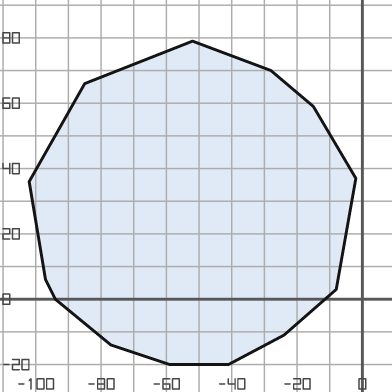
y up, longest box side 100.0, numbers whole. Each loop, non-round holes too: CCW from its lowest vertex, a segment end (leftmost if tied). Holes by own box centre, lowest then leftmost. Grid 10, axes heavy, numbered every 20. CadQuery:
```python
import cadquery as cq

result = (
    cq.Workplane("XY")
    .moveTo(-59.0, -20.0)
    .lineTo(-41.0, -20.0)
    .lineTo(-24.0, -11.0)
    .lineTo(-8.0, 3.0)
    .lineTo(-2.0, 37.0)
    .lineTo(-15.0, 59.0)
    .lineTo(-28.0, 70.0)
    .lineTo(-52.0, 79.0)
    .lineTo(-85.0, 66.0)
    .lineTo(-102.0, 36.0)
    .lineTo(-97.0, 6.0)
    .lineTo(-94.0, 0.0)
    .lineTo(-77.0, -14.0)
    .close()
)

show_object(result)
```